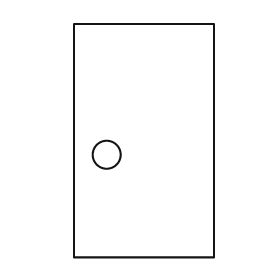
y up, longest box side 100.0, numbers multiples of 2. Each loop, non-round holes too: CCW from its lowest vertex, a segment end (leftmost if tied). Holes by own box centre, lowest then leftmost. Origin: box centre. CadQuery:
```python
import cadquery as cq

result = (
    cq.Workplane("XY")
    .moveTo(-30.0, -50.0)
    .lineTo(30.0, -50.0)
    .lineTo(30.0, 50.0)
    .lineTo(-30.0, 50.0)
    .close()
    .moveTo(-16.0, -6.0)
    .circle(6.0)
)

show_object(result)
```